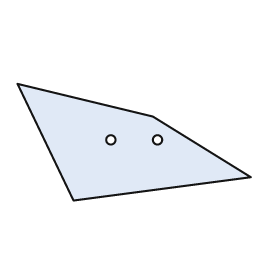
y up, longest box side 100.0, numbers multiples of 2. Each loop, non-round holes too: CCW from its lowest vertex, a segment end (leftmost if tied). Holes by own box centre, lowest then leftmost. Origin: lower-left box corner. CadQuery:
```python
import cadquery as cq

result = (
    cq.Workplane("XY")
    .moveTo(24.0, 0.0)
    .lineTo(100.0, 10.0)
    .lineTo(58.0, 36.0)
    .lineTo(0.0, 50.0)
    .close()
    .moveTo(40.0, 26.0)
    .circle(2.0)
    .moveTo(60.0, 26.0)
    .circle(2.0)
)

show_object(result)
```